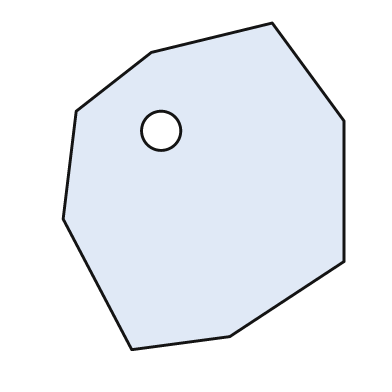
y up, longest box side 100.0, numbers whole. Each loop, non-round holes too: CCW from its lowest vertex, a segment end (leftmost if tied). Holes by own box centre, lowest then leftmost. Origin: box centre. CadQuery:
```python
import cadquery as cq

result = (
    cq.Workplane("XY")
    .moveTo(-22.0, -50.0)
    .lineTo(8.0, -46.0)
    .lineTo(43.0, -23.0)
    .lineTo(43.0, 20.0)
    .lineTo(21.0, 50.0)
    .lineTo(-16.0, 41.0)
    .lineTo(-39.0, 23.0)
    .lineTo(-43.0, -10.0)
    .close()
    .moveTo(-13.0, 17.0)
    .circle(6.0)
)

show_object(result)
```